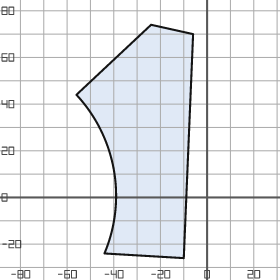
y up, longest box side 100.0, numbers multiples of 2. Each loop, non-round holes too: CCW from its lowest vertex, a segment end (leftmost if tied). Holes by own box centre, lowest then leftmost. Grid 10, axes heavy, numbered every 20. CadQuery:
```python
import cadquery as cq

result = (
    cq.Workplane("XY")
    .moveTo(-10.0, -26.0)
    .lineTo(-6.0, 70.0)
    .lineTo(-24.0, 74.0)
    .lineTo(-56.0, 44.0)
    .threePointArc((-40.0, 12.0), (-44.0, -24.0))
    .close()
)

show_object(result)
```